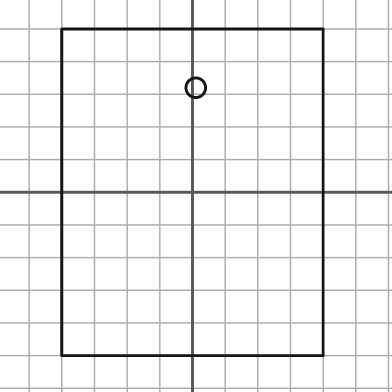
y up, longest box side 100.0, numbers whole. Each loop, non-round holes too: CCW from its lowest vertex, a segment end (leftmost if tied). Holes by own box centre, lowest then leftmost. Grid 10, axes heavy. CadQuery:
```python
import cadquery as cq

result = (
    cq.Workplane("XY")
    .moveTo(-40.0, -50.0)
    .lineTo(40.0, -50.0)
    .lineTo(40.0, 50.0)
    .lineTo(-40.0, 50.0)
    .close()
    .moveTo(1.0, 32.0)
    .circle(3.0)
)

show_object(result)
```